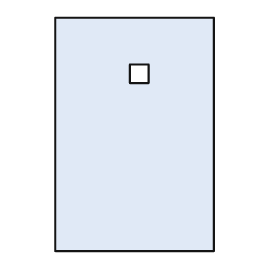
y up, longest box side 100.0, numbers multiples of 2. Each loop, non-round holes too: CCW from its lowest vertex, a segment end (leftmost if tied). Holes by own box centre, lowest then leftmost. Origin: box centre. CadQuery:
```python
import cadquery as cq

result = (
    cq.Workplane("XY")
    .moveTo(-34.0, -50.0)
    .lineTo(34.0, -50.0)
    .lineTo(34.0, 50.0)
    .lineTo(-34.0, 50.0)
    .close()
    .moveTo(-2.0, 22.0)
    .lineTo(6.0, 22.0)
    .lineTo(6.0, 30.0)
    .lineTo(-2.0, 30.0)
    .close()
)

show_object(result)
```